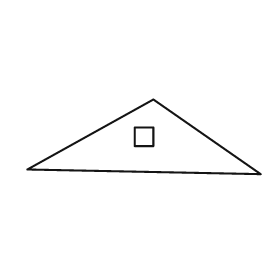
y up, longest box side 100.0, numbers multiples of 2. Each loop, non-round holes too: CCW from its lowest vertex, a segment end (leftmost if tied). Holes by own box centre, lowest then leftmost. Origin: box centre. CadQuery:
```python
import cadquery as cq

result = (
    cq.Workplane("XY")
    .moveTo(50.0, -16.0)
    .lineTo(4.0, 16.0)
    .lineTo(-50.0, -14.0)
    .close()
    .moveTo(-4.0, -4.0)
    .lineTo(4.0, -4.0)
    .lineTo(4.0, 4.0)
    .lineTo(-4.0, 4.0)
    .close()
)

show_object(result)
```